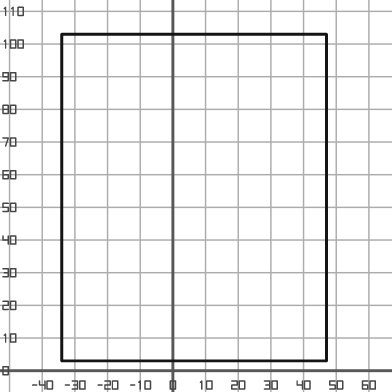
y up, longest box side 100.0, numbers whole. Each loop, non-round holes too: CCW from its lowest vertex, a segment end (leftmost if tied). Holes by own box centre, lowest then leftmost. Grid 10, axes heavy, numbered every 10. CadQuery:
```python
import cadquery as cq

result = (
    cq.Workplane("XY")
    .moveTo(-34.0, 3.0)
    .lineTo(47.0, 3.0)
    .lineTo(47.0, 103.0)
    .lineTo(-34.0, 103.0)
    .close()
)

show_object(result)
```